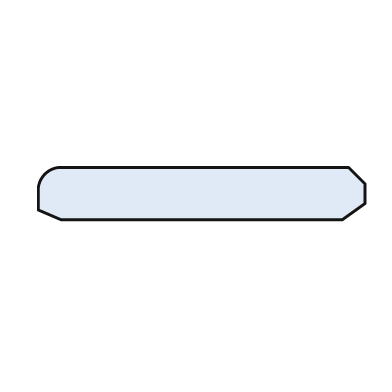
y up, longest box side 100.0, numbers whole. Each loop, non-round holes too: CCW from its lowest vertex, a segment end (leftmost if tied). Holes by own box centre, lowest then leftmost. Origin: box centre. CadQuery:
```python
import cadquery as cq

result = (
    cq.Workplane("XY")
    .moveTo(-43.0, -8.0)
    .lineTo(43.0, -8.0)
    .lineTo(50.0, -3.0)
    .lineTo(50.0, 3.0)
    .lineTo(45.0, 8.0)
    .lineTo(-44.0, 8.0)
    .threePointArc((-48.0, 6.0), (-50.0, 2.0))
    .lineTo(-50.0, -5.0)
    .close()
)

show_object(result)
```